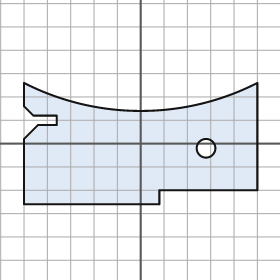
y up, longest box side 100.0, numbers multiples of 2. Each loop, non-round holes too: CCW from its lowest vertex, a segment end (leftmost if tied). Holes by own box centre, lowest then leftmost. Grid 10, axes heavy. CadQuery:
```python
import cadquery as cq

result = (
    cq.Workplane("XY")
    .moveTo(-50.0, -26.0)
    .lineTo(8.0, -26.0)
    .lineTo(8.0, -20.0)
    .lineTo(50.0, -20.0)
    .lineTo(50.0, 26.0)
    .threePointArc((0.0, 14.0), (-50.0, 26.0))
    .lineTo(-50.0, 16.0)
    .lineTo(-46.0, 12.0)
    .lineTo(-36.0, 12.0)
    .lineTo(-36.0, 8.0)
    .lineTo(-44.0, 8.0)
    .lineTo(-50.0, 2.0)
    .close()
    .moveTo(28.0, -2.0)
    .circle(4.0)
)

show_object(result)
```